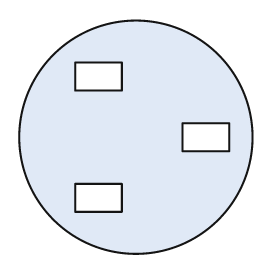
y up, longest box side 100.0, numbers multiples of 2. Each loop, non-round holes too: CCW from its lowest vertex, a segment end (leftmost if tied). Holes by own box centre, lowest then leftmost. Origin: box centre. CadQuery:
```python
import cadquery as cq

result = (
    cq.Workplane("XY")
    .moveTo(0.0, 0.0)
    .circle(50.0)
    .moveTo(-26.0, -32.0)
    .lineTo(-6.0, -32.0)
    .lineTo(-6.0, -20.0)
    .lineTo(-26.0, -20.0)
    .close()
    .moveTo(20.0, -6.0)
    .lineTo(40.0, -6.0)
    .lineTo(40.0, 6.0)
    .lineTo(20.0, 6.0)
    .close()
    .moveTo(-26.0, 20.0)
    .lineTo(-6.0, 20.0)
    .lineTo(-6.0, 32.0)
    .lineTo(-26.0, 32.0)
    .close()
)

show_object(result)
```